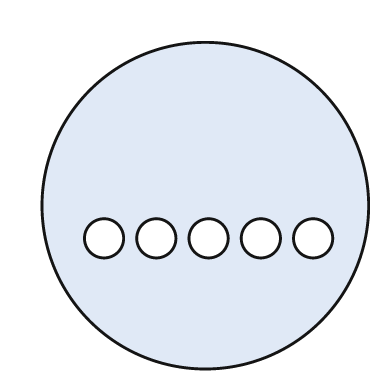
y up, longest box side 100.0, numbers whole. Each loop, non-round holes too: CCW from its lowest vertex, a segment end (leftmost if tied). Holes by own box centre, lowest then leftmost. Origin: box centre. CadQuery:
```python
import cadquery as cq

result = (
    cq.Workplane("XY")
    .moveTo(0.0, 0.0)
    .circle(50.0)
    .moveTo(-31.0, -10.0)
    .circle(6.0)
    .moveTo(-15.0, -10.0)
    .circle(6.0)
    .moveTo(1.0, -10.0)
    .circle(6.0)
    .moveTo(17.0, -10.0)
    .circle(6.0)
    .moveTo(33.0, -10.0)
    .circle(6.0)
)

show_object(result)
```